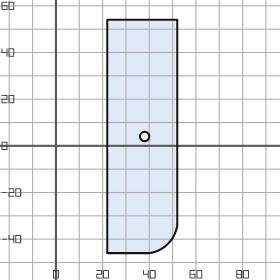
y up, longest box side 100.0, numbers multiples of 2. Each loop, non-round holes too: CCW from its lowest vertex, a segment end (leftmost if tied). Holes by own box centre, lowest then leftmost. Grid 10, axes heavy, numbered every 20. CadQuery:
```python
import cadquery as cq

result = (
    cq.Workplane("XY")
    .moveTo(22.0, -46.0)
    .lineTo(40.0, -46.0)
    .threePointArc((48.0, -42.0), (52.0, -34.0))
    .lineTo(52.0, 54.0)
    .lineTo(22.0, 54.0)
    .close()
    .moveTo(38.0, 4.0)
    .circle(2.0)
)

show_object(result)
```